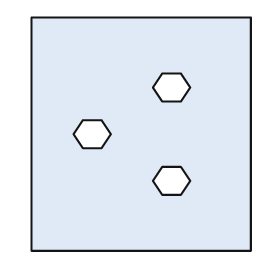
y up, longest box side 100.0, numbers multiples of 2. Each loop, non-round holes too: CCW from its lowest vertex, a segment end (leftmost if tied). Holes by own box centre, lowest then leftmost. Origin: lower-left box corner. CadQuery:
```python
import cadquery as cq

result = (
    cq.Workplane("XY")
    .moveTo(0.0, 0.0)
    .lineTo(94.0, 0.0)
    .lineTo(94.0, 100.0)
    .lineTo(0.0, 100.0)
    .close()
    .moveTo(56.0, 24.0)
    .lineTo(64.0, 24.0)
    .lineTo(68.0, 30.0)
    .lineTo(64.0, 36.0)
    .lineTo(56.0, 36.0)
    .lineTo(52.0, 30.0)
    .close()
    .moveTo(22.0, 44.0)
    .lineTo(30.0, 44.0)
    .lineTo(34.0, 50.0)
    .lineTo(30.0, 56.0)
    .lineTo(22.0, 56.0)
    .lineTo(18.0, 50.0)
    .close()
    .moveTo(56.0, 64.0)
    .lineTo(64.0, 64.0)
    .lineTo(68.0, 70.0)
    .lineTo(64.0, 76.0)
    .lineTo(56.0, 76.0)
    .lineTo(52.0, 70.0)
    .close()
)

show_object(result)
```